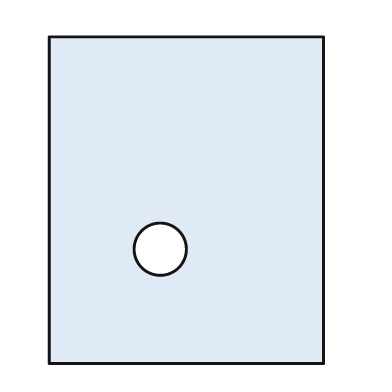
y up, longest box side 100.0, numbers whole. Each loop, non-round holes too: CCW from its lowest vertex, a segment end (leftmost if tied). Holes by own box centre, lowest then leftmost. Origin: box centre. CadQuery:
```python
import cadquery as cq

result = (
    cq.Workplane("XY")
    .moveTo(-42.0, -50.0)
    .lineTo(42.0, -50.0)
    .lineTo(42.0, 50.0)
    .lineTo(-42.0, 50.0)
    .close()
    .moveTo(-8.0, -15.0)
    .circle(8.0)
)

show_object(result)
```